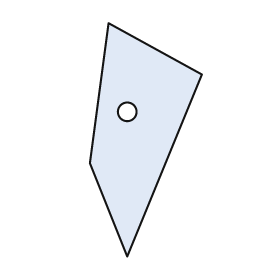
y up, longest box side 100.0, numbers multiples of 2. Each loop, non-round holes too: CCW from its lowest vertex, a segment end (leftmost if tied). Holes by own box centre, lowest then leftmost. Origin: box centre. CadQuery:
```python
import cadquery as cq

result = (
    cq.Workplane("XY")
    .moveTo(-8.0, -50.0)
    .lineTo(24.0, 28.0)
    .lineTo(-16.0, 50.0)
    .lineTo(-24.0, -10.0)
    .close()
    .moveTo(-8.0, 12.0)
    .circle(4.0)
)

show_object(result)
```